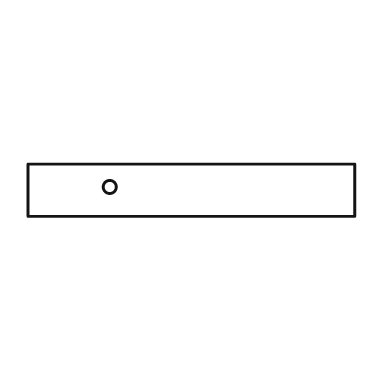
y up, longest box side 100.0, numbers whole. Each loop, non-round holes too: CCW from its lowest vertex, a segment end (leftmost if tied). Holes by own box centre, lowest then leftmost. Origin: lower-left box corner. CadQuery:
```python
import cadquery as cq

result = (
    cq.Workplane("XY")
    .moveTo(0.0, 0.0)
    .lineTo(100.0, 0.0)
    .lineTo(100.0, 16.0)
    .lineTo(0.0, 16.0)
    .close()
    .moveTo(25.0, 9.0)
    .circle(2.0)
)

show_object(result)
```